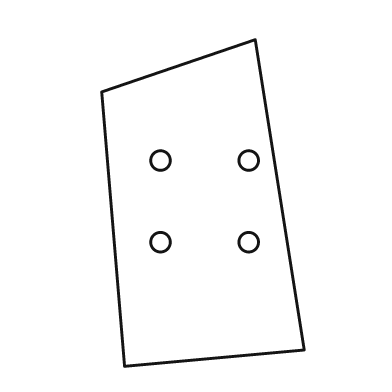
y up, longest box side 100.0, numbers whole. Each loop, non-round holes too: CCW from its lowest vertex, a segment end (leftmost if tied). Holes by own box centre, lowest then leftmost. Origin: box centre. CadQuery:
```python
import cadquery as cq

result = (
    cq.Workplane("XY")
    .moveTo(-24.0, -50.0)
    .lineTo(31.0, -45.0)
    .lineTo(16.0, 50.0)
    .lineTo(-31.0, 34.0)
    .close()
    .moveTo(-13.0, -12.0)
    .circle(3.0)
    .moveTo(14.0, -12.0)
    .circle(3.0)
    .moveTo(-13.0, 13.0)
    .circle(3.0)
    .moveTo(14.0, 13.0)
    .circle(3.0)
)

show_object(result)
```